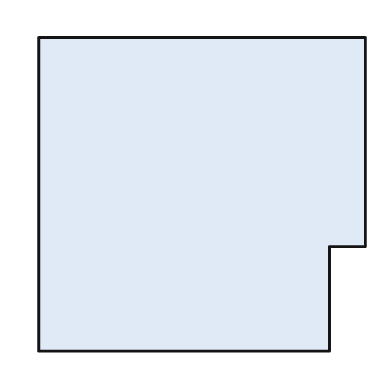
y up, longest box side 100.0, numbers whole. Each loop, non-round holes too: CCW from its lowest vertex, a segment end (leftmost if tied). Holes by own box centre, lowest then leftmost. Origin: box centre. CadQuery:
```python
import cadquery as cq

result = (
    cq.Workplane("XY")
    .moveTo(-50.0, -48.0)
    .lineTo(39.0, -48.0)
    .lineTo(39.0, -16.0)
    .lineTo(50.0, -16.0)
    .lineTo(50.0, 48.0)
    .lineTo(-50.0, 48.0)
    .close()
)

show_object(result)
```